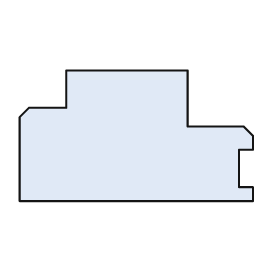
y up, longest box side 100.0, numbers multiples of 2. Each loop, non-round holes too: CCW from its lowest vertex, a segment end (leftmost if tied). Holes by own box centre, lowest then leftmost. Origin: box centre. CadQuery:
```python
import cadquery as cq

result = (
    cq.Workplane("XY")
    .moveTo(-50.0, -28.0)
    .lineTo(50.0, -28.0)
    .lineTo(50.0, -22.0)
    .lineTo(44.0, -22.0)
    .lineTo(44.0, -6.0)
    .lineTo(50.0, -6.0)
    .lineTo(50.0, 0.0)
    .lineTo(46.0, 4.0)
    .lineTo(22.0, 4.0)
    .lineTo(22.0, 28.0)
    .lineTo(-30.0, 28.0)
    .lineTo(-30.0, 12.0)
    .lineTo(-46.0, 12.0)
    .lineTo(-50.0, 8.0)
    .close()
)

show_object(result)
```